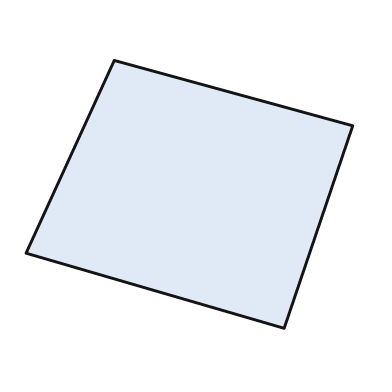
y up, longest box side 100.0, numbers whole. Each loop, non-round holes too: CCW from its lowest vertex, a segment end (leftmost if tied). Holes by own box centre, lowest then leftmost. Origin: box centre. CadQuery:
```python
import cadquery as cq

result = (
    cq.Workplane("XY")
    .moveTo(29.0, -41.0)
    .lineTo(50.0, 21.0)
    .lineTo(-23.0, 41.0)
    .lineTo(-50.0, -18.0)
    .close()
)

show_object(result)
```